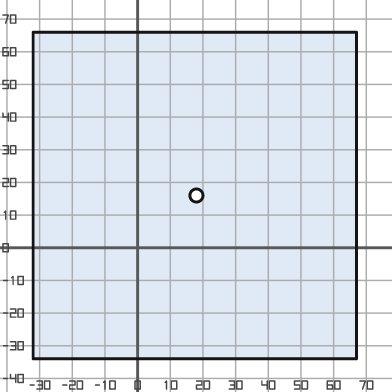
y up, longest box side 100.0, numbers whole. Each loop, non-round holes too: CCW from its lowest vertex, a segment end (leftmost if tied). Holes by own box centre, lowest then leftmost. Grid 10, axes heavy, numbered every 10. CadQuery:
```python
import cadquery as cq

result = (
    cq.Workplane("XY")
    .moveTo(-32.0, -34.0)
    .lineTo(67.0, -34.0)
    .lineTo(67.0, 66.0)
    .lineTo(-32.0, 66.0)
    .close()
    .moveTo(18.0, 16.0)
    .circle(2.0)
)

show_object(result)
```